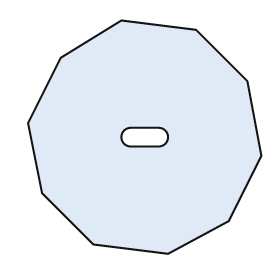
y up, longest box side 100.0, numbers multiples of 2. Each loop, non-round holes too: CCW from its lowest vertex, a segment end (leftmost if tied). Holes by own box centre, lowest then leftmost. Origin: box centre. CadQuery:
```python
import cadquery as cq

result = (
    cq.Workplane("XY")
    .moveTo(10.0, -50.0)
    .lineTo(36.0, -36.0)
    .lineTo(50.0, -8.0)
    .lineTo(44.0, 24.0)
    .lineTo(22.0, 46.0)
    .lineTo(-10.0, 50.0)
    .lineTo(-36.0, 34.0)
    .lineTo(-50.0, 6.0)
    .lineTo(-44.0, -24.0)
    .lineTo(-22.0, -46.0)
    .close()
    .moveTo(-6.0, -4.0)
    .lineTo(6.0, -4.0)
    .threePointArc((10.0, 0.0), (6.0, 4.0))
    .lineTo(-6.0, 4.0)
    .threePointArc((-10.0, 0.0), (-6.0, -4.0))
    .close()
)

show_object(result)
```